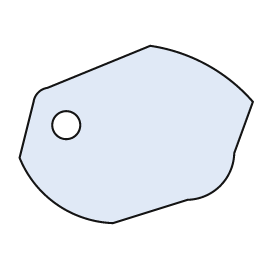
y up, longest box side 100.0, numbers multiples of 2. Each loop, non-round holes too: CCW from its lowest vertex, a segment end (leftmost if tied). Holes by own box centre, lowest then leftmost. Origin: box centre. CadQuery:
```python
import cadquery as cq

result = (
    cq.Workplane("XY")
    .moveTo(-10.0, -38.0)
    .lineTo(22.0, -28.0)
    .threePointArc((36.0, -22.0), (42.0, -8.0))
    .lineTo(50.0, 14.0)
    .threePointArc((30.0, 30.0), (6.0, 38.0))
    .lineTo(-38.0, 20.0)
    .threePointArc((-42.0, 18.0), (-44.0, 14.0))
    .lineTo(-50.0, -10.0)
    .threePointArc((-34.0, -30.0), (-10.0, -38.0))
    .close()
    .moveTo(-30.0, 4.0)
    .circle(6.0)
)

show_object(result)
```